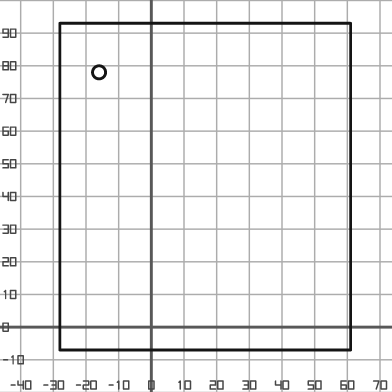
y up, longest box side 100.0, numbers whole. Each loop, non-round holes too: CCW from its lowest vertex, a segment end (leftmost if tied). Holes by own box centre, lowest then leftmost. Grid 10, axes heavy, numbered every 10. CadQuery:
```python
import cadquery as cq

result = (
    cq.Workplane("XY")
    .moveTo(-28.0, -7.0)
    .lineTo(61.0, -7.0)
    .lineTo(61.0, 93.0)
    .lineTo(-28.0, 93.0)
    .close()
    .moveTo(-16.0, 78.0)
    .circle(2.0)
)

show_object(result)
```